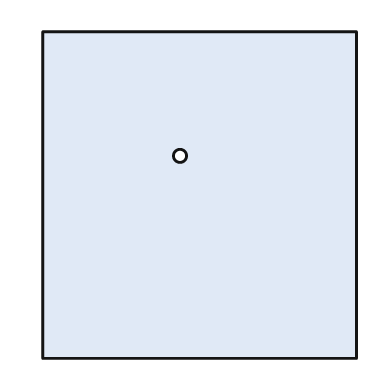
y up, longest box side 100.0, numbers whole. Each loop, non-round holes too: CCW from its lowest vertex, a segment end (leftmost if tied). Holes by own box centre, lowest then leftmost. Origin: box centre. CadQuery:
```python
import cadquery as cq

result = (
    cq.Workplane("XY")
    .moveTo(-48.0, -50.0)
    .lineTo(48.0, -50.0)
    .lineTo(48.0, 50.0)
    .lineTo(-48.0, 50.0)
    .close()
    .moveTo(-6.0, 12.0)
    .circle(2.0)
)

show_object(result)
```